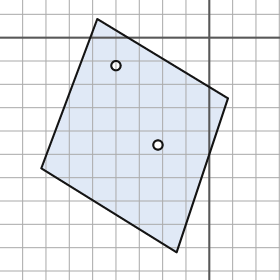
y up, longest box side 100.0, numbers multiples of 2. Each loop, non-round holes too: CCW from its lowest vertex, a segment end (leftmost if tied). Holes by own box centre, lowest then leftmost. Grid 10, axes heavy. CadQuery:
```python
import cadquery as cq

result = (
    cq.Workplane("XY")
    .moveTo(-14.0, -92.0)
    .lineTo(8.0, -26.0)
    .lineTo(-48.0, 8.0)
    .lineTo(-72.0, -56.0)
    .close()
    .moveTo(-22.0, -46.0)
    .circle(2.0)
    .moveTo(-40.0, -12.0)
    .circle(2.0)
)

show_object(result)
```